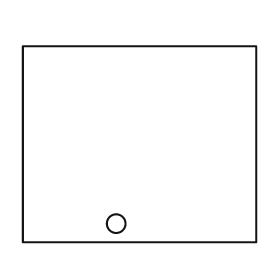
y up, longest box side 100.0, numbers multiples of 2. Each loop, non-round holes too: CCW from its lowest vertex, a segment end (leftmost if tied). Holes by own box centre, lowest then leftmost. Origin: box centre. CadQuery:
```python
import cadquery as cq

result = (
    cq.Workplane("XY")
    .moveTo(-50.0, -42.0)
    .lineTo(50.0, -42.0)
    .lineTo(50.0, 42.0)
    .lineTo(-50.0, 42.0)
    .close()
    .moveTo(-10.0, -34.0)
    .circle(4.0)
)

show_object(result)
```